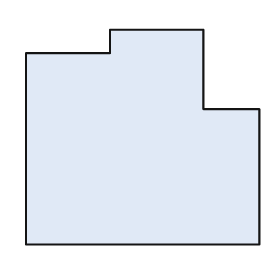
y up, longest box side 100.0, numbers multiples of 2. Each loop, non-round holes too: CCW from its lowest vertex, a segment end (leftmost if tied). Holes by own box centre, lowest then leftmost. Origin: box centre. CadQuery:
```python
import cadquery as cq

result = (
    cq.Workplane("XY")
    .moveTo(-50.0, -46.0)
    .lineTo(50.0, -46.0)
    .lineTo(50.0, 12.0)
    .lineTo(26.0, 12.0)
    .lineTo(26.0, 46.0)
    .lineTo(-14.0, 46.0)
    .lineTo(-14.0, 36.0)
    .lineTo(-50.0, 36.0)
    .close()
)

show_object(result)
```